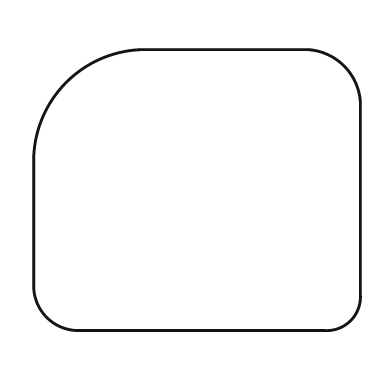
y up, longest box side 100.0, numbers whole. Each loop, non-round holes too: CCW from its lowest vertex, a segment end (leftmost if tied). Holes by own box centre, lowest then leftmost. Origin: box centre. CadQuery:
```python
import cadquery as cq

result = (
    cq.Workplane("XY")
    .moveTo(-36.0, -43.0)
    .lineTo(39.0, -43.0)
    .threePointArc((47.0, -40.0), (50.0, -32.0))
    .lineTo(50.0, 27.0)
    .threePointArc((45.0, 38.0), (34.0, 43.0))
    .lineTo(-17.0, 43.0)
    .threePointArc((-40.0, 33.0), (-50.0, 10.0))
    .lineTo(-50.0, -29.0)
    .threePointArc((-46.0, -39.0), (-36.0, -43.0))
    .close()
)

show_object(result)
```